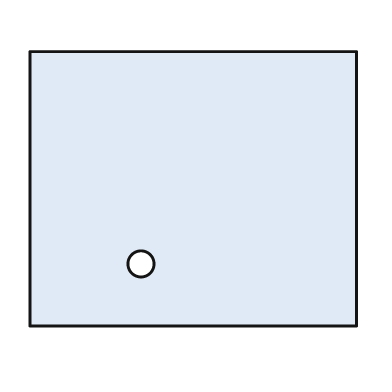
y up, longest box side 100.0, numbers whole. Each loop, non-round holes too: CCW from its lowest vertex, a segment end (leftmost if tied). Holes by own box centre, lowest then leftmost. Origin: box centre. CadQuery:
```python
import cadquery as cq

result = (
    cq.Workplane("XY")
    .moveTo(-50.0, -42.0)
    .lineTo(50.0, -42.0)
    .lineTo(50.0, 42.0)
    .lineTo(-50.0, 42.0)
    .close()
    .moveTo(-16.0, -23.0)
    .circle(4.0)
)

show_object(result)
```